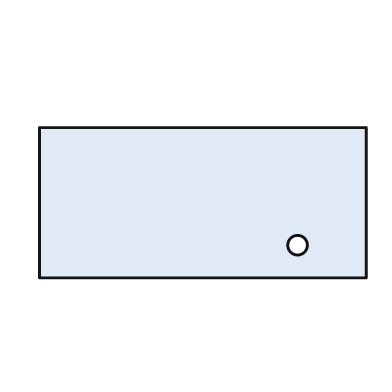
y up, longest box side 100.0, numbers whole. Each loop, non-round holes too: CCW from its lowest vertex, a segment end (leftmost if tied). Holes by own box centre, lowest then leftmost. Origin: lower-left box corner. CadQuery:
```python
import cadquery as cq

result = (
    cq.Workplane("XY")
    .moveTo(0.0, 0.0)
    .lineTo(100.0, 0.0)
    .lineTo(100.0, 46.0)
    .lineTo(0.0, 46.0)
    .close()
    .moveTo(79.0, 10.0)
    .circle(3.0)
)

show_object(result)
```